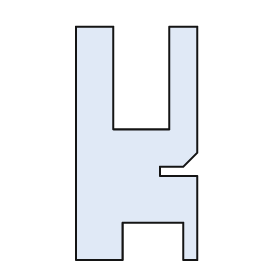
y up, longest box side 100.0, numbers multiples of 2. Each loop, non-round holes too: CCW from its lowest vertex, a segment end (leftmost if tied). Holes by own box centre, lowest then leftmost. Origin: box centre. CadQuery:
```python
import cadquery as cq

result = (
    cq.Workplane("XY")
    .moveTo(-26.0, -50.0)
    .lineTo(-6.0, -50.0)
    .lineTo(-6.0, -34.0)
    .lineTo(20.0, -34.0)
    .lineTo(20.0, -50.0)
    .lineTo(26.0, -50.0)
    .lineTo(26.0, -14.0)
    .lineTo(10.0, -14.0)
    .lineTo(10.0, -10.0)
    .lineTo(20.0, -10.0)
    .lineTo(26.0, -4.0)
    .lineTo(26.0, 50.0)
    .lineTo(14.0, 50.0)
    .lineTo(14.0, 6.0)
    .lineTo(-10.0, 6.0)
    .lineTo(-10.0, 50.0)
    .lineTo(-26.0, 50.0)
    .close()
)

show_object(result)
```